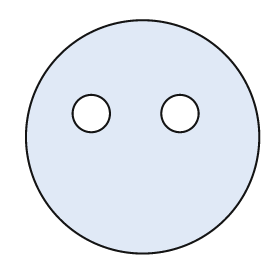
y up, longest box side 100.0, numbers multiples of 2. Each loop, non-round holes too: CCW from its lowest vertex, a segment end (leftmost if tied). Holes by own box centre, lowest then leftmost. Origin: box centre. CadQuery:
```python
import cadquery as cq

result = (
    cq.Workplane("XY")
    .moveTo(0.0, 0.0)
    .circle(50.0)
    .moveTo(-22.0, 10.0)
    .circle(8.0)
    .moveTo(16.0, 10.0)
    .circle(8.0)
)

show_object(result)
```